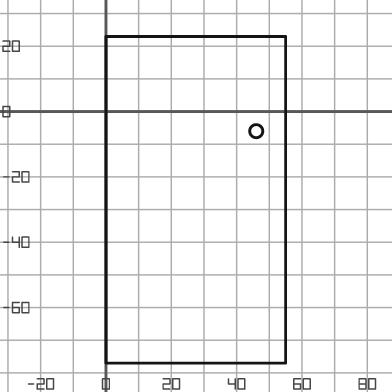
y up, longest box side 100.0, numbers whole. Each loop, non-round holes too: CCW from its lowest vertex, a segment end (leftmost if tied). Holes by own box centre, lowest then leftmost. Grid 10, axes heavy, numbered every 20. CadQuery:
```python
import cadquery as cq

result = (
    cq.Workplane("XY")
    .moveTo(0.0, -77.0)
    .lineTo(55.0, -77.0)
    .lineTo(55.0, 23.0)
    .lineTo(0.0, 23.0)
    .close()
    .moveTo(46.0, -6.0)
    .circle(2.0)
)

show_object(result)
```